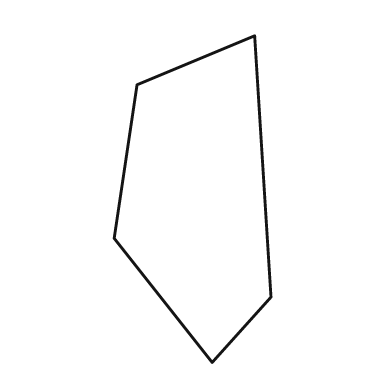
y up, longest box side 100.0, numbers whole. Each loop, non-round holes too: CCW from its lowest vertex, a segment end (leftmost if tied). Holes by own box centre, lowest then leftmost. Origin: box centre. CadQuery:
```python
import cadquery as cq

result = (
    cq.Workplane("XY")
    .moveTo(6.0, -50.0)
    .lineTo(24.0, -30.0)
    .lineTo(19.0, 50.0)
    .lineTo(-17.0, 35.0)
    .lineTo(-24.0, -12.0)
    .close()
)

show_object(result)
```